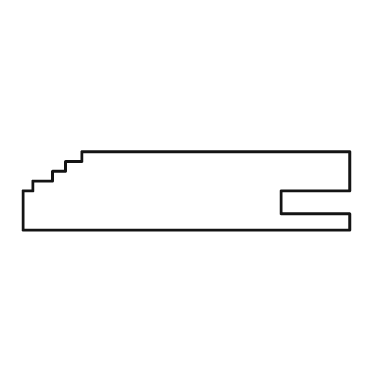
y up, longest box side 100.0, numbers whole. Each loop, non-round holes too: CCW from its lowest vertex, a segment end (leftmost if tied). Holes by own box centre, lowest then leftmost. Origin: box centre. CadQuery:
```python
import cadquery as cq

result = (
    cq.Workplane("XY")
    .moveTo(-50.0, -12.0)
    .lineTo(50.0, -12.0)
    .lineTo(50.0, -7.0)
    .lineTo(29.0, -7.0)
    .lineTo(29.0, 0.0)
    .lineTo(50.0, 0.0)
    .lineTo(50.0, 12.0)
    .lineTo(-32.0, 12.0)
    .lineTo(-32.0, 9.0)
    .lineTo(-37.0, 9.0)
    .lineTo(-37.0, 6.0)
    .lineTo(-41.0, 6.0)
    .lineTo(-41.0, 3.0)
    .lineTo(-47.0, 3.0)
    .lineTo(-47.0, 0.0)
    .lineTo(-50.0, 0.0)
    .close()
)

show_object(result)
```